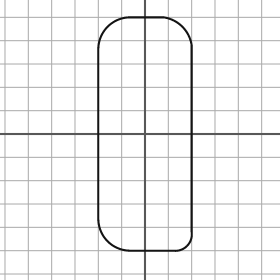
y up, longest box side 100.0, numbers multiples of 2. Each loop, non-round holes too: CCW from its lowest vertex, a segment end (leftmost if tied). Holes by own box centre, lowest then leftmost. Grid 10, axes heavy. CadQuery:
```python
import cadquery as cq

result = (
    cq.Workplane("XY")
    .moveTo(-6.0, -50.0)
    .lineTo(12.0, -50.0)
    .threePointArc((18.0, -48.0), (20.0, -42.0))
    .lineTo(20.0, 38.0)
    .threePointArc((16.0, 46.0), (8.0, 50.0))
    .lineTo(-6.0, 50.0)
    .threePointArc((-16.0, 46.0), (-20.0, 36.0))
    .lineTo(-20.0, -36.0)
    .threePointArc((-16.0, -46.0), (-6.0, -50.0))
    .close()
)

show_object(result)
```